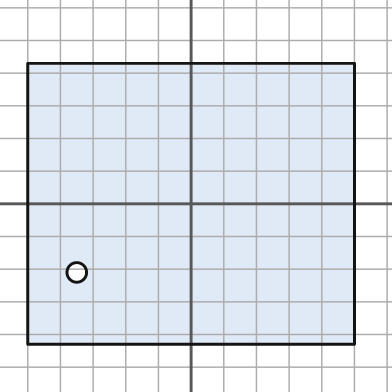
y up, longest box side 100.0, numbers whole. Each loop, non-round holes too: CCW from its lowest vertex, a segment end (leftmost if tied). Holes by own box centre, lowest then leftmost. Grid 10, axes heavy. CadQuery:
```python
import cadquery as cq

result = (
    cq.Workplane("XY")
    .moveTo(-50.0, -43.0)
    .lineTo(50.0, -43.0)
    .lineTo(50.0, 43.0)
    .lineTo(-50.0, 43.0)
    .close()
    .moveTo(-35.0, -21.0)
    .circle(3.0)
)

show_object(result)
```